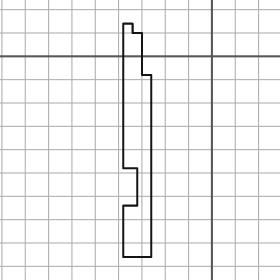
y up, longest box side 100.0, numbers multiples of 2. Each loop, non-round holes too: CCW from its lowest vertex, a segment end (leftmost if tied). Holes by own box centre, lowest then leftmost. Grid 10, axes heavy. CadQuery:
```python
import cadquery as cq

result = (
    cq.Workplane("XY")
    .moveTo(-38.0, -86.0)
    .lineTo(-26.0, -86.0)
    .lineTo(-26.0, -8.0)
    .lineTo(-30.0, -8.0)
    .lineTo(-30.0, 10.0)
    .lineTo(-34.0, 10.0)
    .lineTo(-34.0, 14.0)
    .lineTo(-38.0, 14.0)
    .lineTo(-38.0, -48.0)
    .lineTo(-32.0, -48.0)
    .lineTo(-32.0, -64.0)
    .lineTo(-38.0, -64.0)
    .close()
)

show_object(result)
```